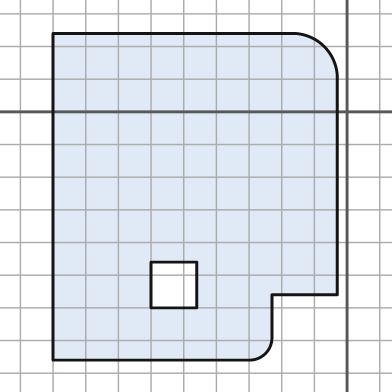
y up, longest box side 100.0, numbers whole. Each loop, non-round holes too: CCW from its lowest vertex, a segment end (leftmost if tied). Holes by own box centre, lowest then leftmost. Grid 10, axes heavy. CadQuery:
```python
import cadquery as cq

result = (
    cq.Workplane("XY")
    .moveTo(-90.0, -76.0)
    .lineTo(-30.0, -76.0)
    .threePointArc((-25.0, -74.0), (-23.0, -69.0))
    .lineTo(-23.0, -56.0)
    .lineTo(-3.0, -56.0)
    .lineTo(-3.0, 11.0)
    .threePointArc((-7.0, 20.0), (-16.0, 24.0))
    .lineTo(-90.0, 24.0)
    .close()
    .moveTo(-60.0, -60.0)
    .lineTo(-46.0, -60.0)
    .lineTo(-46.0, -46.0)
    .lineTo(-60.0, -46.0)
    .close()
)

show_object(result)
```